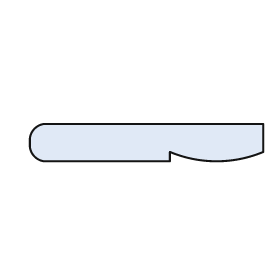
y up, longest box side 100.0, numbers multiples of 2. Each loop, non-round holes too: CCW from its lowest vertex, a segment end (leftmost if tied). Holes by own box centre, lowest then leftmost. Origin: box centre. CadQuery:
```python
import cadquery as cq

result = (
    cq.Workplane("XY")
    .moveTo(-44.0, -8.0)
    .lineTo(10.0, -8.0)
    .lineTo(10.0, -4.0)
    .threePointArc((30.0, -8.0), (50.0, -4.0))
    .lineTo(50.0, 8.0)
    .lineTo(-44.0, 8.0)
    .threePointArc((-48.0, 6.0), (-50.0, 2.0))
    .lineTo(-50.0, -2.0)
    .threePointArc((-48.0, -6.0), (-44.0, -8.0))
    .close()
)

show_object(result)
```